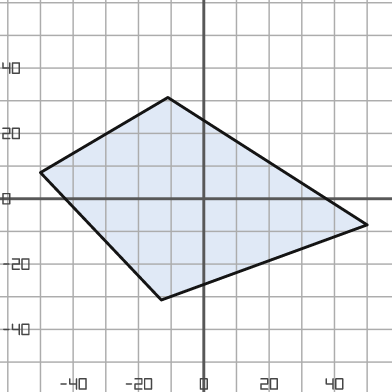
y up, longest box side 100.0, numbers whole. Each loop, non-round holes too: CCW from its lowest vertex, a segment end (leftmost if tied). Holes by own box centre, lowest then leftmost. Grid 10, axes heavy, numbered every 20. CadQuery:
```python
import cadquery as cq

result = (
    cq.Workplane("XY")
    .moveTo(-13.0, -31.0)
    .lineTo(50.0, -8.0)
    .lineTo(-11.0, 31.0)
    .lineTo(-50.0, 8.0)
    .close()
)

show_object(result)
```